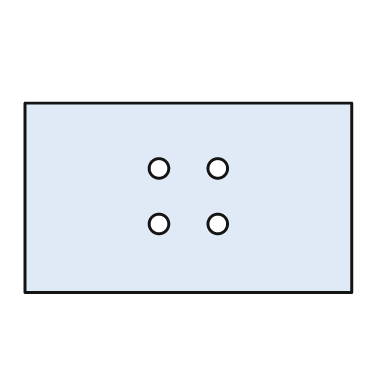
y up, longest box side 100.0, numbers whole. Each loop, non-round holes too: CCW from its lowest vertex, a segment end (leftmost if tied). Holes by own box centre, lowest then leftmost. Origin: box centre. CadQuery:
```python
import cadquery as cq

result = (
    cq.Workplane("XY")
    .moveTo(-50.0, -29.0)
    .lineTo(50.0, -29.0)
    .lineTo(50.0, 29.0)
    .lineTo(-50.0, 29.0)
    .close()
    .moveTo(-9.0, -8.0)
    .circle(3.0)
    .moveTo(9.0, -8.0)
    .circle(3.0)
    .moveTo(-9.0, 9.0)
    .circle(3.0)
    .moveTo(9.0, 9.0)
    .circle(3.0)
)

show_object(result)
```